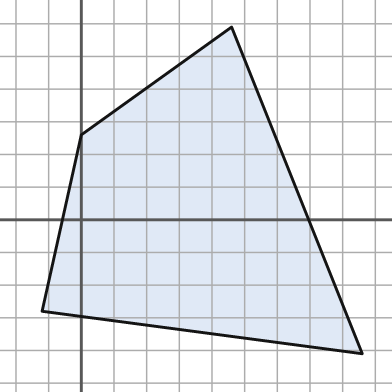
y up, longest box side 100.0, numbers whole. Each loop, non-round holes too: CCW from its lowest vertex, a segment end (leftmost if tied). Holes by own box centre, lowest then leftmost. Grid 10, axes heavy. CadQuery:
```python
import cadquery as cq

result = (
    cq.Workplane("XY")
    .moveTo(86.0, -41.0)
    .lineTo(46.0, 59.0)
    .lineTo(0.0, 26.0)
    .lineTo(-12.0, -28.0)
    .close()
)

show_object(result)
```